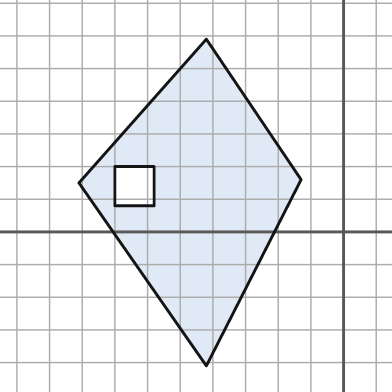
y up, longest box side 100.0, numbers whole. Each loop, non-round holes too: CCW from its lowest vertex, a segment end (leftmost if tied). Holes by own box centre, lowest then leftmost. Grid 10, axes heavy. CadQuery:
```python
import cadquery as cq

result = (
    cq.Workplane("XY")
    .moveTo(-42.0, -41.0)
    .lineTo(-13.0, 16.0)
    .lineTo(-42.0, 59.0)
    .lineTo(-81.0, 15.0)
    .close()
    .moveTo(-70.0, 8.0)
    .lineTo(-58.0, 8.0)
    .lineTo(-58.0, 20.0)
    .lineTo(-70.0, 20.0)
    .close()
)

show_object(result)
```